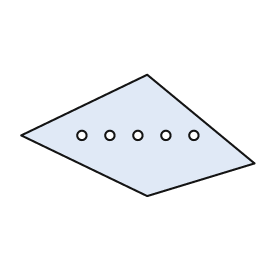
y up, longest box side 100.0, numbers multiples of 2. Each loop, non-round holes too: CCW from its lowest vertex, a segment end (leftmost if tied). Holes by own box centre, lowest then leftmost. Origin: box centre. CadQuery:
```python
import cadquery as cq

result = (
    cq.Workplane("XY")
    .moveTo(4.0, -26.0)
    .lineTo(50.0, -12.0)
    .lineTo(4.0, 26.0)
    .lineTo(-50.0, 0.0)
    .close()
    .moveTo(-24.0, 0.0)
    .circle(2.0)
    .moveTo(-12.0, 0.0)
    .circle(2.0)
    .moveTo(0.0, 0.0)
    .circle(2.0)
    .moveTo(12.0, 0.0)
    .circle(2.0)
    .moveTo(24.0, 0.0)
    .circle(2.0)
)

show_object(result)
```